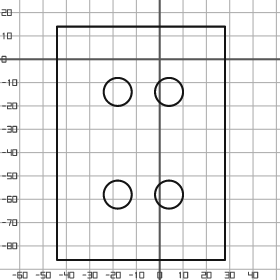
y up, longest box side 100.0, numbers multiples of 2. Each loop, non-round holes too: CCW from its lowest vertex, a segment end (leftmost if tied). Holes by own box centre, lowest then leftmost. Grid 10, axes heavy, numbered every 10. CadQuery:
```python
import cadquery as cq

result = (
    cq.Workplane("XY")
    .moveTo(-44.0, -86.0)
    .lineTo(28.0, -86.0)
    .lineTo(28.0, 14.0)
    .lineTo(-44.0, 14.0)
    .close()
    .moveTo(-18.0, -58.0)
    .circle(6.0)
    .moveTo(4.0, -58.0)
    .circle(6.0)
    .moveTo(-18.0, -14.0)
    .circle(6.0)
    .moveTo(4.0, -14.0)
    .circle(6.0)
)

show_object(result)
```